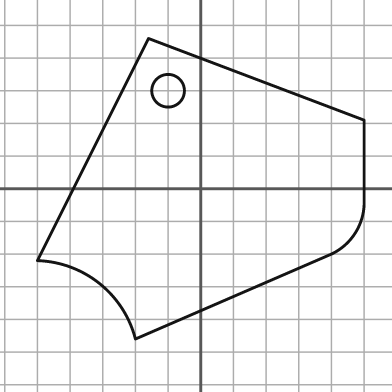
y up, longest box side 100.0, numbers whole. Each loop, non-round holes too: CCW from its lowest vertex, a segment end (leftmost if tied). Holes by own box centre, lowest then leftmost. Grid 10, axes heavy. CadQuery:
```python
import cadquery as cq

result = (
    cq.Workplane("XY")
    .moveTo(-20.0, -46.0)
    .lineTo(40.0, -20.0)
    .threePointArc((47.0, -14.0), (50.0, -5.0))
    .lineTo(50.0, 21.0)
    .lineTo(-16.0, 46.0)
    .lineTo(-50.0, -22.0)
    .threePointArc((-31.0, -29.0), (-20.0, -46.0))
    .close()
    .moveTo(-10.0, 30.0)
    .circle(5.0)
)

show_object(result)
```